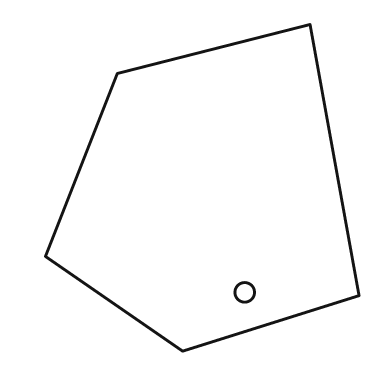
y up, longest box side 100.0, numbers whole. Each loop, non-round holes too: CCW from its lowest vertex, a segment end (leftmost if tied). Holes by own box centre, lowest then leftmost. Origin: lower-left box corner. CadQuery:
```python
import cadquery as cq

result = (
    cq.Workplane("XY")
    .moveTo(42.0, 0.0)
    .lineTo(96.0, 17.0)
    .lineTo(81.0, 100.0)
    .lineTo(22.0, 85.0)
    .lineTo(0.0, 29.0)
    .close()
    .moveTo(61.0, 18.0)
    .circle(3.0)
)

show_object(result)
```